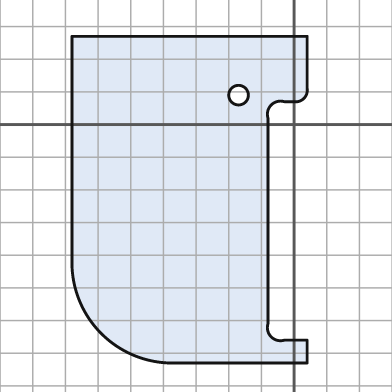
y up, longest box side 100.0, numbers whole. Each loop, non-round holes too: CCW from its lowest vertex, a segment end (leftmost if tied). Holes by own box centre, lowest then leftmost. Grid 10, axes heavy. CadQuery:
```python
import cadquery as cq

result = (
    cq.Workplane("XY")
    .moveTo(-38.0, -73.0)
    .lineTo(4.0, -73.0)
    .lineTo(4.0, -66.0)
    .lineTo(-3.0, -66.0)
    .threePointArc((-7.0, -65.0), (-8.0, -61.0))
    .lineTo(-8.0, 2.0)
    .threePointArc((-7.0, 6.0), (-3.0, 7.0))
    .lineTo(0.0, 7.0)
    .threePointArc((3.0, 8.0), (4.0, 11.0))
    .lineTo(4.0, 27.0)
    .lineTo(-68.0, 27.0)
    .lineTo(-68.0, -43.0)
    .threePointArc((-59.0, -64.0), (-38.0, -73.0))
    .close()
    .moveTo(-17.0, 9.0)
    .circle(3.0)
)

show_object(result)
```